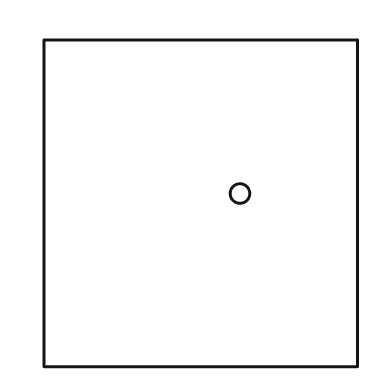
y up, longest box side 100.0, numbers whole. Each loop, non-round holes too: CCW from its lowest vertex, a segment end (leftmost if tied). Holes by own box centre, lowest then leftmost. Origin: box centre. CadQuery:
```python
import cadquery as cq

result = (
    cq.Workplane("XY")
    .moveTo(-48.0, -50.0)
    .lineTo(48.0, -50.0)
    .lineTo(48.0, 50.0)
    .lineTo(-48.0, 50.0)
    .close()
    .moveTo(12.0, 3.0)
    .circle(3.0)
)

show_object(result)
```